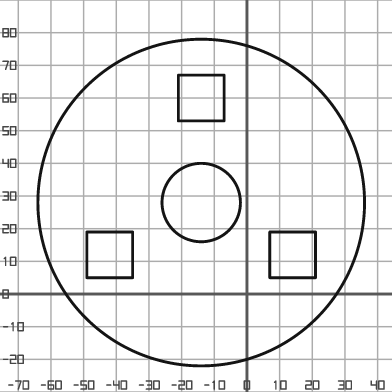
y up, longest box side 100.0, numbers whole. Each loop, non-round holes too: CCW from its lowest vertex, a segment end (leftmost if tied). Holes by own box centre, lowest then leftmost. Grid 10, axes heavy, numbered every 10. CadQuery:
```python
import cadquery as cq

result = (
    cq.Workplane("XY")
    .moveTo(-14.0, 28.0)
    .circle(50.0)
    .moveTo(-49.0, 5.0)
    .lineTo(-35.0, 5.0)
    .lineTo(-35.0, 19.0)
    .lineTo(-49.0, 19.0)
    .close()
    .moveTo(7.0, 5.0)
    .lineTo(21.0, 5.0)
    .lineTo(21.0, 19.0)
    .lineTo(7.0, 19.0)
    .close()
    .moveTo(-14.0, 28.0)
    .circle(12.0)
    .moveTo(-21.0, 53.0)
    .lineTo(-7.0, 53.0)
    .lineTo(-7.0, 67.0)
    .lineTo(-21.0, 67.0)
    .close()
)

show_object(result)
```